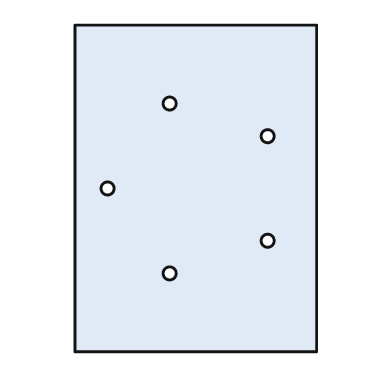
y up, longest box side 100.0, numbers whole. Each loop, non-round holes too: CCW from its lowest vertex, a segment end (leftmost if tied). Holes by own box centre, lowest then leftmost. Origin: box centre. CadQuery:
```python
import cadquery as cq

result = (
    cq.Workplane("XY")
    .moveTo(-37.0, -50.0)
    .lineTo(37.0, -50.0)
    .lineTo(37.0, 50.0)
    .lineTo(-37.0, 50.0)
    .close()
    .moveTo(-8.0, -26.0)
    .circle(2.0)
    .moveTo(22.0, -16.0)
    .circle(2.0)
    .moveTo(-27.0, 0.0)
    .circle(2.0)
    .moveTo(22.0, 16.0)
    .circle(2.0)
    .moveTo(-8.0, 26.0)
    .circle(2.0)
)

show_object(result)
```